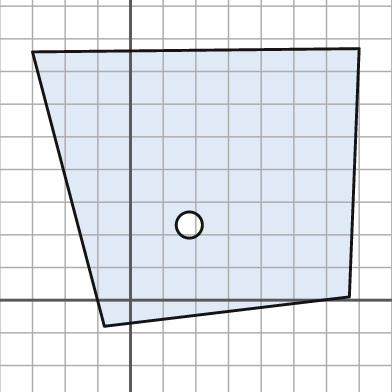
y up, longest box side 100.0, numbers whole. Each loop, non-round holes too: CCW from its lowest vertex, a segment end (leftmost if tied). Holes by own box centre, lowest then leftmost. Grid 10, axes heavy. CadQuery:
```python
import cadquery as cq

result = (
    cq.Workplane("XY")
    .moveTo(-8.0, -8.0)
    .lineTo(67.0, 1.0)
    .lineTo(70.0, 77.0)
    .lineTo(-30.0, 76.0)
    .close()
    .moveTo(18.0, 23.0)
    .circle(4.0)
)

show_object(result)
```